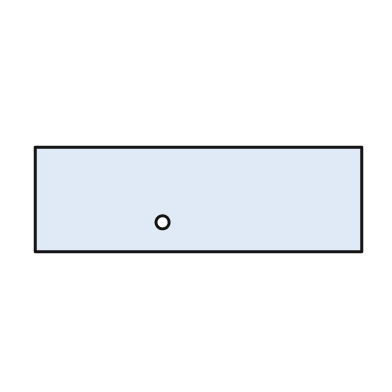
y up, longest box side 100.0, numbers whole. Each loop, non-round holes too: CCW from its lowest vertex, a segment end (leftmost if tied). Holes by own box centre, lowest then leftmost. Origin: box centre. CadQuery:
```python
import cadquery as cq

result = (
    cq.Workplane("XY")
    .moveTo(-50.0, -16.0)
    .lineTo(50.0, -16.0)
    .lineTo(50.0, 16.0)
    .lineTo(-50.0, 16.0)
    .close()
    .moveTo(-11.0, -7.0)
    .circle(2.0)
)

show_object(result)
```